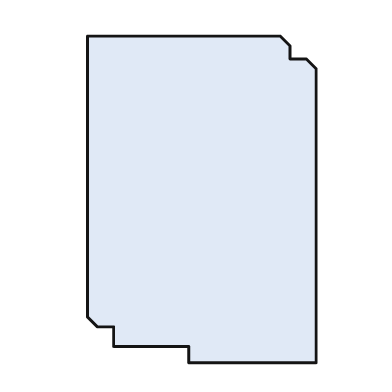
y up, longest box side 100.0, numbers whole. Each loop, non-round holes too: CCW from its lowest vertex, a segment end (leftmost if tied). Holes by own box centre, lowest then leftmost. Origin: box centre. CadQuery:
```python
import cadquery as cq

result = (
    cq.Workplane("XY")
    .moveTo(-4.0, -50.0)
    .lineTo(35.0, -50.0)
    .lineTo(35.0, 40.0)
    .lineTo(32.0, 43.0)
    .lineTo(27.0, 43.0)
    .lineTo(27.0, 47.0)
    .lineTo(24.0, 50.0)
    .lineTo(-35.0, 50.0)
    .lineTo(-35.0, -36.0)
    .lineTo(-32.0, -39.0)
    .lineTo(-27.0, -39.0)
    .lineTo(-27.0, -45.0)
    .lineTo(-4.0, -45.0)
    .close()
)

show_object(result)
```